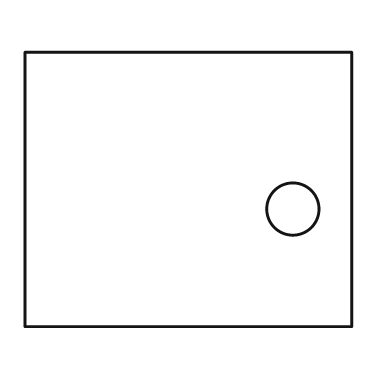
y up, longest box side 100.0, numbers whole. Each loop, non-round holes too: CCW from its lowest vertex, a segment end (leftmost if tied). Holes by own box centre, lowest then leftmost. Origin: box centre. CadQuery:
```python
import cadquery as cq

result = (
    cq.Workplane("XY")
    .moveTo(-50.0, -42.0)
    .lineTo(50.0, -42.0)
    .lineTo(50.0, 42.0)
    .lineTo(-50.0, 42.0)
    .close()
    .moveTo(32.0, -6.0)
    .circle(8.0)
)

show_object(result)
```